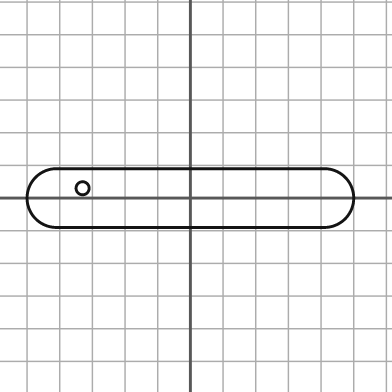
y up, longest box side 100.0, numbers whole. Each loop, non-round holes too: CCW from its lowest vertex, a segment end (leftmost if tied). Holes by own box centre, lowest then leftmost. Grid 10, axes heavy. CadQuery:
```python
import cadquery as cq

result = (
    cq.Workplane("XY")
    .moveTo(-41.0, -9.0)
    .lineTo(41.0, -9.0)
    .threePointArc((50.0, 0.0), (41.0, 9.0))
    .lineTo(-41.0, 9.0)
    .threePointArc((-50.0, 0.0), (-41.0, -9.0))
    .close()
    .moveTo(-33.0, 3.0)
    .circle(2.0)
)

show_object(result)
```